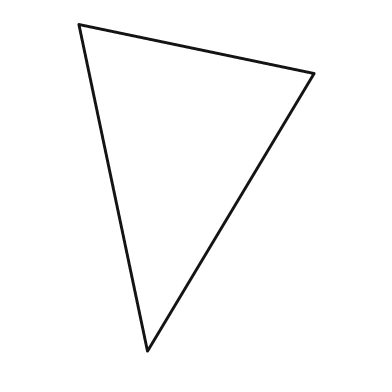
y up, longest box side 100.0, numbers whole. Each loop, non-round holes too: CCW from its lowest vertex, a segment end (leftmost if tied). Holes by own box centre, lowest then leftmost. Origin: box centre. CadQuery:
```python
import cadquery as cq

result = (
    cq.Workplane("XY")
    .moveTo(-15.0, -50.0)
    .lineTo(36.0, 35.0)
    .lineTo(-36.0, 50.0)
    .close()
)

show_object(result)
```